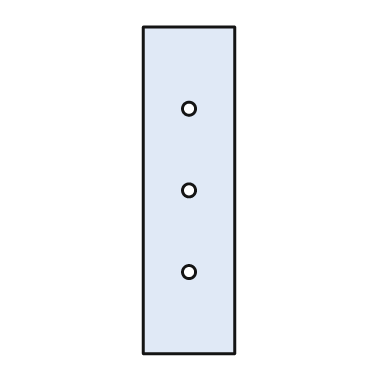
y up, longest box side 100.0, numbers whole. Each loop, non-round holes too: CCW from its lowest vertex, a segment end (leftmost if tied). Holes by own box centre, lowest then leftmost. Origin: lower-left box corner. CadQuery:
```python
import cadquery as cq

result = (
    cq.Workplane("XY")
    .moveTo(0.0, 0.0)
    .lineTo(28.0, 0.0)
    .lineTo(28.0, 100.0)
    .lineTo(0.0, 100.0)
    .close()
    .moveTo(14.0, 25.0)
    .circle(2.0)
    .moveTo(14.0, 50.0)
    .circle(2.0)
    .moveTo(14.0, 75.0)
    .circle(2.0)
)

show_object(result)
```